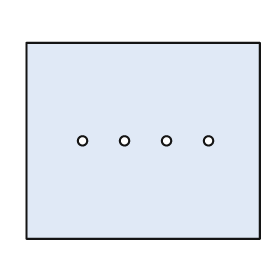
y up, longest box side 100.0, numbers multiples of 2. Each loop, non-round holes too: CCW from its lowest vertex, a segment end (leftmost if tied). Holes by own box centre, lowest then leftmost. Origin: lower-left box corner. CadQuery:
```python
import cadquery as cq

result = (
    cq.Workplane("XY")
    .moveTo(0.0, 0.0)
    .lineTo(100.0, 0.0)
    .lineTo(100.0, 84.0)
    .lineTo(0.0, 84.0)
    .close()
    .moveTo(24.0, 42.0)
    .circle(2.0)
    .moveTo(42.0, 42.0)
    .circle(2.0)
    .moveTo(60.0, 42.0)
    .circle(2.0)
    .moveTo(78.0, 42.0)
    .circle(2.0)
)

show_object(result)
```